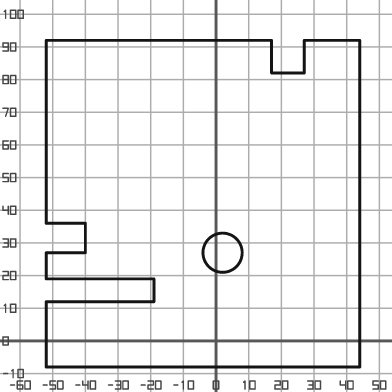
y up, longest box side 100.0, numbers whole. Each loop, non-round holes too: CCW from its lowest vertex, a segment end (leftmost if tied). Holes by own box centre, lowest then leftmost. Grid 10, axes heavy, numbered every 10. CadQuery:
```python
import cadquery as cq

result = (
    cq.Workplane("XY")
    .moveTo(-52.0, -8.0)
    .lineTo(44.0, -8.0)
    .lineTo(44.0, 92.0)
    .lineTo(27.0, 92.0)
    .lineTo(27.0, 82.0)
    .lineTo(17.0, 82.0)
    .lineTo(17.0, 92.0)
    .lineTo(-52.0, 92.0)
    .lineTo(-52.0, 36.0)
    .lineTo(-40.0, 36.0)
    .lineTo(-40.0, 27.0)
    .lineTo(-52.0, 27.0)
    .lineTo(-52.0, 19.0)
    .lineTo(-19.0, 19.0)
    .lineTo(-19.0, 12.0)
    .lineTo(-52.0, 12.0)
    .close()
    .moveTo(2.0, 27.0)
    .circle(6.0)
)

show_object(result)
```